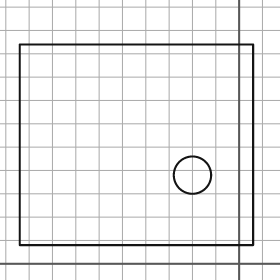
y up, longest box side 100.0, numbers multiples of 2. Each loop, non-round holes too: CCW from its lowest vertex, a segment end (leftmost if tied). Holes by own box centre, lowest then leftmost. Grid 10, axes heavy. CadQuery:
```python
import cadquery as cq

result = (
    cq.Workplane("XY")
    .moveTo(-94.0, 8.0)
    .lineTo(6.0, 8.0)
    .lineTo(6.0, 94.0)
    .lineTo(-94.0, 94.0)
    .close()
    .moveTo(-20.0, 38.0)
    .circle(8.0)
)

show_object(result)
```